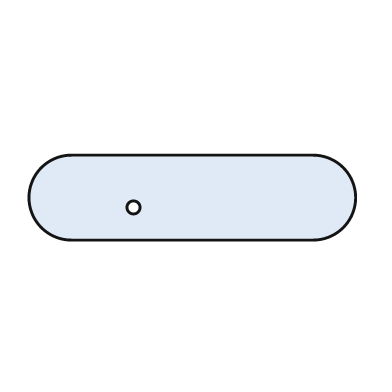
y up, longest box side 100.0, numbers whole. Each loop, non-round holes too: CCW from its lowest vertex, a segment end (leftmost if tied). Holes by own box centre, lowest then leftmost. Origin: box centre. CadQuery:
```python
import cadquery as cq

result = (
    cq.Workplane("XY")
    .moveTo(-37.0, -13.0)
    .lineTo(37.0, -13.0)
    .threePointArc((50.0, 0.0), (37.0, 13.0))
    .lineTo(-37.0, 13.0)
    .threePointArc((-50.0, 0.0), (-37.0, -13.0))
    .close()
    .moveTo(-18.0, -3.0)
    .circle(2.0)
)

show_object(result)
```